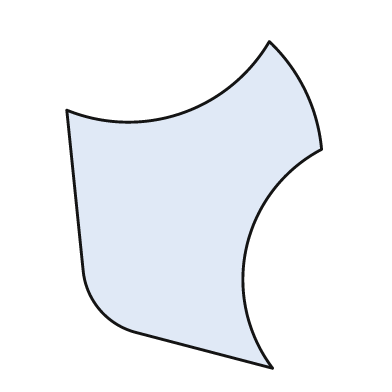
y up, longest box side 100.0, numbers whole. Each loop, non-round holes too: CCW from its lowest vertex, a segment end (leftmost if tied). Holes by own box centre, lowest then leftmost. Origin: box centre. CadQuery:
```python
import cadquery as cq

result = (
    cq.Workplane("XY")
    .moveTo(24.0, -50.0)
    .threePointArc((16.0, -13.0), (39.0, 17.0))
    .threePointArc((34.0, 35.0), (23.0, 50.0))
    .threePointArc((-4.0, 28.0), (-39.0, 29.0))
    .lineTo(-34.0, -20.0)
    .threePointArc((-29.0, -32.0), (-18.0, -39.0))
    .close()
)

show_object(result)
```